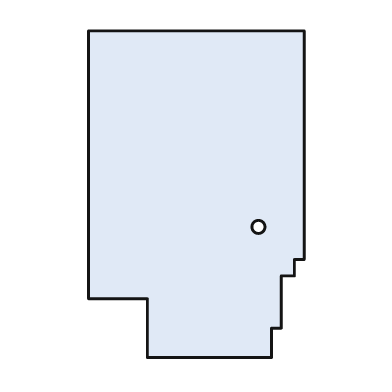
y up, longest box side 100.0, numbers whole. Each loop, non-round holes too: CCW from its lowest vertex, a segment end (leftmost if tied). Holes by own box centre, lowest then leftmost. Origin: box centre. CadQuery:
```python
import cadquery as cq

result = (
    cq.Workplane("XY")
    .moveTo(-15.0, -50.0)
    .lineTo(23.0, -50.0)
    .lineTo(23.0, -41.0)
    .lineTo(26.0, -41.0)
    .lineTo(26.0, -25.0)
    .lineTo(30.0, -25.0)
    .lineTo(30.0, -20.0)
    .lineTo(33.0, -20.0)
    .lineTo(33.0, 50.0)
    .lineTo(-33.0, 50.0)
    .lineTo(-33.0, -32.0)
    .lineTo(-15.0, -32.0)
    .close()
    .moveTo(19.0, -10.0)
    .circle(2.0)
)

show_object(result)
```